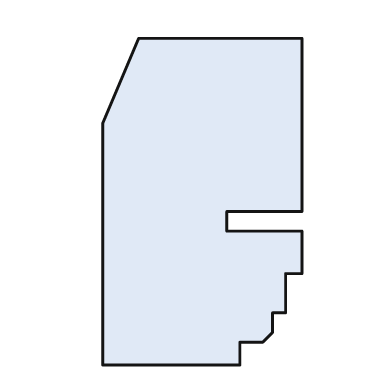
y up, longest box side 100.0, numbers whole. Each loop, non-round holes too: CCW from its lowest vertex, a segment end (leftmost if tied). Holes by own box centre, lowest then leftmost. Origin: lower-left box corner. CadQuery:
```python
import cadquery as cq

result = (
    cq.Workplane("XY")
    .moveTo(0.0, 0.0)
    .lineTo(42.0, 0.0)
    .lineTo(42.0, 7.0)
    .lineTo(49.0, 7.0)
    .lineTo(52.0, 10.0)
    .lineTo(52.0, 16.0)
    .lineTo(56.0, 16.0)
    .lineTo(56.0, 28.0)
    .lineTo(61.0, 28.0)
    .lineTo(61.0, 41.0)
    .lineTo(38.0, 41.0)
    .lineTo(38.0, 47.0)
    .lineTo(61.0, 47.0)
    .lineTo(61.0, 100.0)
    .lineTo(11.0, 100.0)
    .lineTo(0.0, 74.0)
    .close()
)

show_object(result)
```